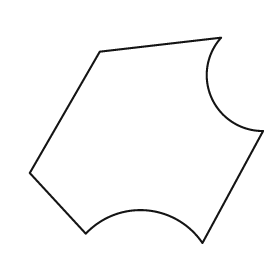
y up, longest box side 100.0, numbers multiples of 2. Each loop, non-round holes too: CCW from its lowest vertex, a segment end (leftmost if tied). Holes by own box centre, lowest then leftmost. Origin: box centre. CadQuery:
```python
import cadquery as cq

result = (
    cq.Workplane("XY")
    .moveTo(24.0, -44.0)
    .lineTo(50.0, 4.0)
    .threePointArc((28.0, 18.0), (32.0, 44.0))
    .lineTo(-20.0, 38.0)
    .lineTo(-50.0, -14.0)
    .lineTo(-26.0, -40.0)
    .threePointArc((0.0, -30.0), (24.0, -44.0))
    .close()
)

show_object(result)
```